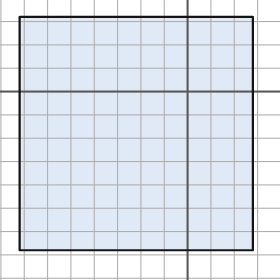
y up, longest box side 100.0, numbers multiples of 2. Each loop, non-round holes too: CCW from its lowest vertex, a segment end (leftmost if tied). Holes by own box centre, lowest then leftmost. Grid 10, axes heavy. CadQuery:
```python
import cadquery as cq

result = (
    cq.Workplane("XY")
    .moveTo(-72.0, -68.0)
    .lineTo(28.0, -68.0)
    .lineTo(28.0, 32.0)
    .lineTo(-72.0, 32.0)
    .close()
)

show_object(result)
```